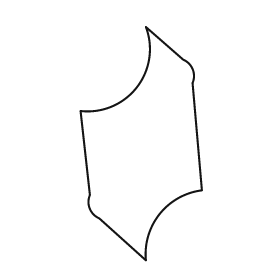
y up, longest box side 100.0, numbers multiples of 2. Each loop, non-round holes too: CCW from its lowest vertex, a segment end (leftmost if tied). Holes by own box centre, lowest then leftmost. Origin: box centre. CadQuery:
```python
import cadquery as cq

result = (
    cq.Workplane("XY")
    .moveTo(2.0, -50.0)
    .threePointArc((8.0, -30.0), (26.0, -20.0))
    .lineTo(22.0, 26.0)
    .threePointArc((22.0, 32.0), (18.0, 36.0))
    .lineTo(2.0, 50.0)
    .threePointArc((-2.0, 24.0), (-26.0, 14.0))
    .lineTo(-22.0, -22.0)
    .threePointArc((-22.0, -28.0), (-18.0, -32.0))
    .close()
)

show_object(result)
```